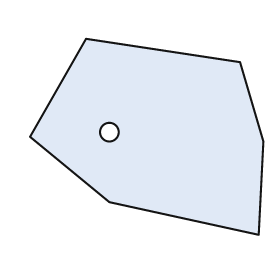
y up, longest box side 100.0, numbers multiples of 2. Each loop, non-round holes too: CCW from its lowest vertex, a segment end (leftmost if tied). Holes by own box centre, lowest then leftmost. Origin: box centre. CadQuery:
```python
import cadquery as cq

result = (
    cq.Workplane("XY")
    .moveTo(48.0, -42.0)
    .lineTo(50.0, -2.0)
    .lineTo(40.0, 32.0)
    .lineTo(-26.0, 42.0)
    .lineTo(-50.0, 0.0)
    .lineTo(-16.0, -28.0)
    .close()
    .moveTo(-16.0, 2.0)
    .circle(4.0)
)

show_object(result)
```